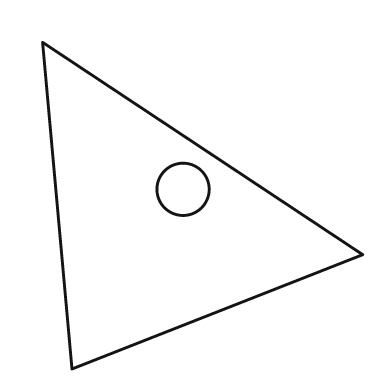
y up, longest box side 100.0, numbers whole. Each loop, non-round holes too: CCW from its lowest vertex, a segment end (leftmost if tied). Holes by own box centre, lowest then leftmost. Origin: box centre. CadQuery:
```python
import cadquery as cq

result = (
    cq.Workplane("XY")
    .moveTo(-40.0, -50.0)
    .lineTo(49.0, -15.0)
    .lineTo(-49.0, 50.0)
    .close()
    .moveTo(-6.0, 5.0)
    .circle(8.0)
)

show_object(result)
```